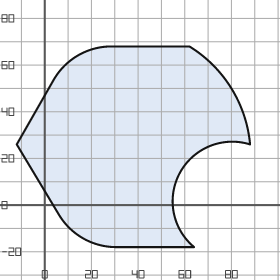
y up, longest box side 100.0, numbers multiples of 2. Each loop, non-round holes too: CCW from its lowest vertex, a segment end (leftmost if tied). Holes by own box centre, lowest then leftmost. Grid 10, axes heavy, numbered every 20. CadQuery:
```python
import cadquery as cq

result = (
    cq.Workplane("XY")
    .moveTo(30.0, -18.0)
    .lineTo(64.0, -18.0)
    .threePointArc((58.0, 14.0), (88.0, 26.0))
    .threePointArc((80.0, 50.0), (62.0, 68.0))
    .lineTo(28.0, 68.0)
    .threePointArc((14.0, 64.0), (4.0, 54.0))
    .lineTo(-12.0, 26.0)
    .lineTo(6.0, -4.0)
    .threePointArc((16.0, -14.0), (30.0, -18.0))
    .close()
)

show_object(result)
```